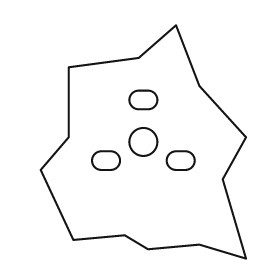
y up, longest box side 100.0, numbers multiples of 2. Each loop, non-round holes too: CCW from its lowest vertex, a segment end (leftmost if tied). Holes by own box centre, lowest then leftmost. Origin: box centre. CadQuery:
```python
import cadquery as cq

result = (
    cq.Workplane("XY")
    .moveTo(44.0, -50.0)
    .lineTo(34.0, -16.0)
    .lineTo(44.0, 2.0)
    .lineTo(24.0, 24.0)
    .lineTo(14.0, 50.0)
    .lineTo(-2.0, 36.0)
    .lineTo(-32.0, 32.0)
    .lineTo(-32.0, 2.0)
    .lineTo(-44.0, -12.0)
    .lineTo(-30.0, -42.0)
    .lineTo(-8.0, -40.0)
    .lineTo(2.0, -46.0)
    .lineTo(24.0, -44.0)
    .close()
    .moveTo(-18.0, -12.0)
    .lineTo(-14.0, -12.0)
    .threePointArc((-10.0, -8.0), (-14.0, -4.0))
    .lineTo(-18.0, -4.0)
    .threePointArc((-22.0, -8.0), (-18.0, -12.0))
    .close()
    .moveTo(14.0, -12.0)
    .lineTo(18.0, -12.0)
    .threePointArc((22.0, -8.0), (18.0, -4.0))
    .lineTo(14.0, -4.0)
    .threePointArc((10.0, -8.0), (14.0, -12.0))
    .close()
    .moveTo(0.0, 0.0)
    .circle(6.0)
    .moveTo(-2.0, 14.0)
    .lineTo(2.0, 14.0)
    .threePointArc((6.0, 18.0), (2.0, 22.0))
    .lineTo(-2.0, 22.0)
    .threePointArc((-6.0, 18.0), (-2.0, 14.0))
    .close()
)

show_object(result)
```